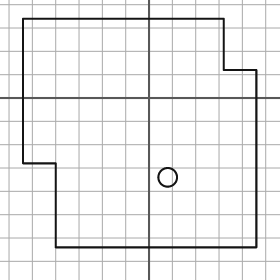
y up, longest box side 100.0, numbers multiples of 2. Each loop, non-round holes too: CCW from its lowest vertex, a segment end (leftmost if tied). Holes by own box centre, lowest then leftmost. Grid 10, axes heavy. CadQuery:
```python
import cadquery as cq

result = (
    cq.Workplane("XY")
    .moveTo(-40.0, -64.0)
    .lineTo(46.0, -64.0)
    .lineTo(46.0, 12.0)
    .lineTo(32.0, 12.0)
    .lineTo(32.0, 34.0)
    .lineTo(-54.0, 34.0)
    .lineTo(-54.0, -28.0)
    .lineTo(-40.0, -28.0)
    .close()
    .moveTo(8.0, -34.0)
    .circle(4.0)
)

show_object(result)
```